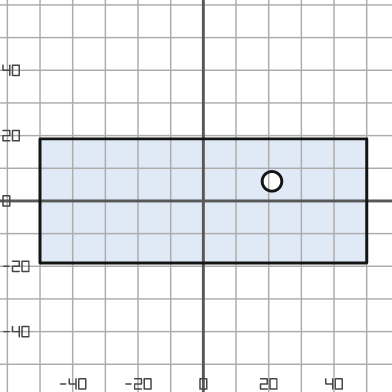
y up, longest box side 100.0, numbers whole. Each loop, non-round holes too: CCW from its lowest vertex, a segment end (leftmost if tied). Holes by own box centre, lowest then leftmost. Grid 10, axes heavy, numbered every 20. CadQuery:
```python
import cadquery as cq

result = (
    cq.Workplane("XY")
    .moveTo(-50.0, -19.0)
    .lineTo(50.0, -19.0)
    .lineTo(50.0, 19.0)
    .lineTo(-50.0, 19.0)
    .close()
    .moveTo(21.0, 6.0)
    .circle(3.0)
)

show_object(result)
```